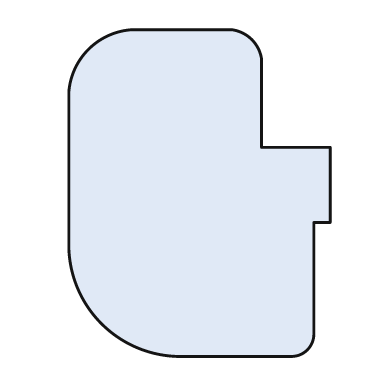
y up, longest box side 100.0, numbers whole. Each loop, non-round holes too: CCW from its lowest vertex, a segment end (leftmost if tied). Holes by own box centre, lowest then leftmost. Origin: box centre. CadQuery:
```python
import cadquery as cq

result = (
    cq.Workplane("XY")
    .moveTo(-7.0, -50.0)
    .lineTo(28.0, -50.0)
    .threePointArc((33.0, -48.0), (35.0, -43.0))
    .lineTo(35.0, -9.0)
    .lineTo(40.0, -9.0)
    .lineTo(40.0, 14.0)
    .lineTo(19.0, 14.0)
    .lineTo(19.0, 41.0)
    .threePointArc((16.0, 47.0), (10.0, 50.0))
    .lineTo(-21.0, 50.0)
    .threePointArc((-34.0, 44.0), (-40.0, 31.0))
    .lineTo(-40.0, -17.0)
    .threePointArc((-30.0, -40.0), (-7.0, -50.0))
    .close()
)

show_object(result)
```